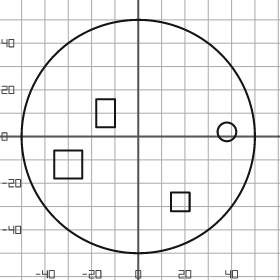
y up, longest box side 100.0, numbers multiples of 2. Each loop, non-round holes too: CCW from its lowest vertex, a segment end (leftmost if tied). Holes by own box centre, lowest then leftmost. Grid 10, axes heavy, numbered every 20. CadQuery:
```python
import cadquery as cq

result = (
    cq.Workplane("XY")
    .moveTo(0.0, 0.0)
    .circle(50.0)
    .moveTo(14.0, -32.0)
    .lineTo(22.0, -32.0)
    .lineTo(22.0, -24.0)
    .lineTo(14.0, -24.0)
    .close()
    .moveTo(-36.0, -18.0)
    .lineTo(-24.0, -18.0)
    .lineTo(-24.0, -6.0)
    .lineTo(-36.0, -6.0)
    .close()
    .moveTo(38.0, 2.0)
    .circle(4.0)
    .moveTo(-18.0, 4.0)
    .lineTo(-10.0, 4.0)
    .lineTo(-10.0, 16.0)
    .lineTo(-18.0, 16.0)
    .close()
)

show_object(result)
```